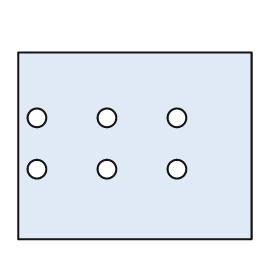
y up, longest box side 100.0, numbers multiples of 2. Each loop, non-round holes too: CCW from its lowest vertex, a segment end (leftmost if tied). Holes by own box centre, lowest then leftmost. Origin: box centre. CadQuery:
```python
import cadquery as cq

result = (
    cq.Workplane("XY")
    .moveTo(-50.0, -40.0)
    .lineTo(50.0, -40.0)
    .lineTo(50.0, 40.0)
    .lineTo(-50.0, 40.0)
    .close()
    .moveTo(-42.0, -10.0)
    .circle(4.0)
    .moveTo(-12.0, -10.0)
    .circle(4.0)
    .moveTo(18.0, -10.0)
    .circle(4.0)
    .moveTo(-42.0, 12.0)
    .circle(4.0)
    .moveTo(-12.0, 12.0)
    .circle(4.0)
    .moveTo(18.0, 12.0)
    .circle(4.0)
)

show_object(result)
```